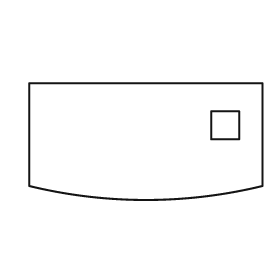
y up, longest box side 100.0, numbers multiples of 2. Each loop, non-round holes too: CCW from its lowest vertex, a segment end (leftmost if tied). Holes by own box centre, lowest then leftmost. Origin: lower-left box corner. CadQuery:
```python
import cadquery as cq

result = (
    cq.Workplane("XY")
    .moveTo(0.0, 6.0)
    .threePointArc((50.0, 0.0), (100.0, 6.0))
    .lineTo(100.0, 50.0)
    .lineTo(0.0, 50.0)
    .close()
    .moveTo(78.0, 26.0)
    .lineTo(90.0, 26.0)
    .lineTo(90.0, 38.0)
    .lineTo(78.0, 38.0)
    .close()
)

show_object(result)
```